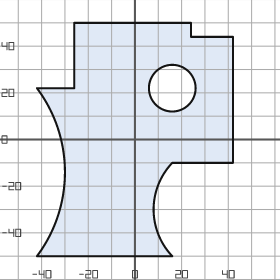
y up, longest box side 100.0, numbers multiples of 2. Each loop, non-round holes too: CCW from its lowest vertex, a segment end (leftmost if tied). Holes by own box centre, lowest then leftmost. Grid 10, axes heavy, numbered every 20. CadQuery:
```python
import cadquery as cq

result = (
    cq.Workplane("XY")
    .moveTo(-42.0, -50.0)
    .lineTo(16.0, -50.0)
    .threePointArc((8.0, -30.0), (16.0, -10.0))
    .lineTo(42.0, -10.0)
    .lineTo(42.0, 44.0)
    .lineTo(24.0, 44.0)
    .lineTo(24.0, 50.0)
    .lineTo(-26.0, 50.0)
    .lineTo(-26.0, 22.0)
    .lineTo(-42.0, 22.0)
    .threePointArc((-30.0, -14.0), (-42.0, -50.0))
    .close()
    .moveTo(16.0, 22.0)
    .circle(10.0)
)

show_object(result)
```